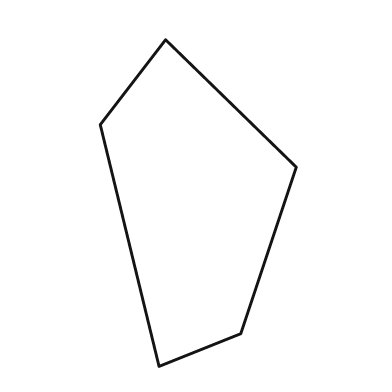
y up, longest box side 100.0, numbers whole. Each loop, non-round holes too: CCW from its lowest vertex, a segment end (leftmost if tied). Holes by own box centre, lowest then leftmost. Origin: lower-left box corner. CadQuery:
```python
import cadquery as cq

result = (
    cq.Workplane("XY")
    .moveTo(18.0, 0.0)
    .lineTo(43.0, 10.0)
    .lineTo(60.0, 61.0)
    .lineTo(20.0, 100.0)
    .lineTo(0.0, 74.0)
    .close()
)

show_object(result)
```